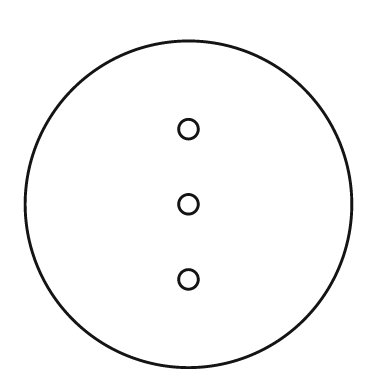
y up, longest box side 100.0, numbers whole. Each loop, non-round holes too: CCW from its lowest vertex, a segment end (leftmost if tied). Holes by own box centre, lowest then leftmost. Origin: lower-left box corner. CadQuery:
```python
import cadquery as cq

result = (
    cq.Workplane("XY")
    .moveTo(50.0, 50.0)
    .circle(50.0)
    .moveTo(50.0, 27.0)
    .circle(3.0)
    .moveTo(50.0, 50.0)
    .circle(3.0)
    .moveTo(50.0, 73.0)
    .circle(3.0)
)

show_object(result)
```